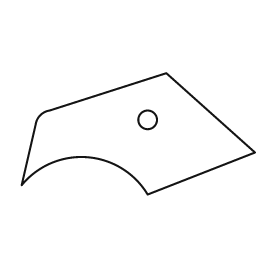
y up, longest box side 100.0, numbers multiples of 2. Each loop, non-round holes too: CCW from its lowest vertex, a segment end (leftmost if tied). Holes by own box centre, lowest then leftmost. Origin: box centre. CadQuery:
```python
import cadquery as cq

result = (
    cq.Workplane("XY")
    .moveTo(4.0, -26.0)
    .lineTo(50.0, -8.0)
    .lineTo(12.0, 26.0)
    .lineTo(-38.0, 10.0)
    .threePointArc((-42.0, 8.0), (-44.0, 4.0))
    .lineTo(-50.0, -22.0)
    .threePointArc((-22.0, -10.0), (4.0, -26.0))
    .close()
    .moveTo(4.0, 6.0)
    .circle(4.0)
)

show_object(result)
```